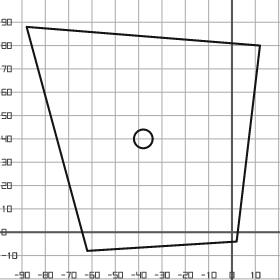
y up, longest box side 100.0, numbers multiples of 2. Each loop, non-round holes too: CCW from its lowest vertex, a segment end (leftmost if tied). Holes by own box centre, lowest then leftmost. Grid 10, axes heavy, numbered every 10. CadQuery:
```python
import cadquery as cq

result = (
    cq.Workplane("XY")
    .moveTo(-62.0, -8.0)
    .lineTo(2.0, -4.0)
    .lineTo(12.0, 80.0)
    .lineTo(-88.0, 88.0)
    .close()
    .moveTo(-38.0, 40.0)
    .circle(4.0)
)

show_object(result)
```